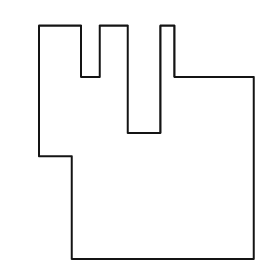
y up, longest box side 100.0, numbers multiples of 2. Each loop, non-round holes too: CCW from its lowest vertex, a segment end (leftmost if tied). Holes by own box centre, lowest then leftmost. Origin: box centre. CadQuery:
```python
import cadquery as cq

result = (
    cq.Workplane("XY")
    .moveTo(-32.0, -50.0)
    .lineTo(46.0, -50.0)
    .lineTo(46.0, 28.0)
    .lineTo(12.0, 28.0)
    .lineTo(12.0, 50.0)
    .lineTo(6.0, 50.0)
    .lineTo(6.0, 4.0)
    .lineTo(-8.0, 4.0)
    .lineTo(-8.0, 50.0)
    .lineTo(-20.0, 50.0)
    .lineTo(-20.0, 28.0)
    .lineTo(-28.0, 28.0)
    .lineTo(-28.0, 50.0)
    .lineTo(-46.0, 50.0)
    .lineTo(-46.0, -6.0)
    .lineTo(-32.0, -6.0)
    .close()
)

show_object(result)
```